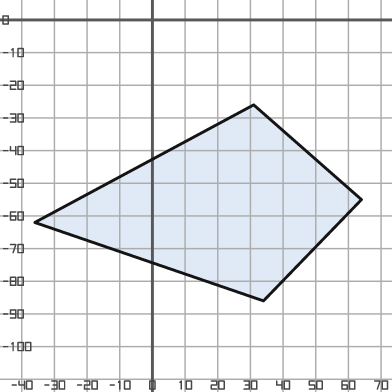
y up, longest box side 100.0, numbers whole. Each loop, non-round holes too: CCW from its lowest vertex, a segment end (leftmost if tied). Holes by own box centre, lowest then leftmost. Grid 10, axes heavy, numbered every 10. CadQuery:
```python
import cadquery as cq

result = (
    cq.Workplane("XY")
    .moveTo(34.0, -86.0)
    .lineTo(64.0, -55.0)
    .lineTo(31.0, -26.0)
    .lineTo(-36.0, -62.0)
    .close()
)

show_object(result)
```